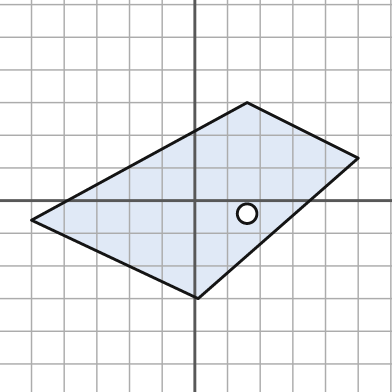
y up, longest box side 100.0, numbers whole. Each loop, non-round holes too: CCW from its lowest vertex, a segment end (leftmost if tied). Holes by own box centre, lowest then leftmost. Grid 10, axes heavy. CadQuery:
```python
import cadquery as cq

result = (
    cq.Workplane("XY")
    .moveTo(1.0, -30.0)
    .lineTo(50.0, 13.0)
    .lineTo(16.0, 30.0)
    .lineTo(-50.0, -6.0)
    .close()
    .moveTo(16.0, -4.0)
    .circle(3.0)
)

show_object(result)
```